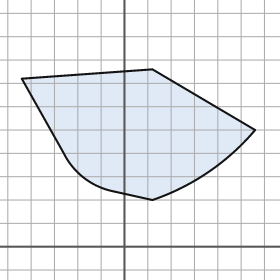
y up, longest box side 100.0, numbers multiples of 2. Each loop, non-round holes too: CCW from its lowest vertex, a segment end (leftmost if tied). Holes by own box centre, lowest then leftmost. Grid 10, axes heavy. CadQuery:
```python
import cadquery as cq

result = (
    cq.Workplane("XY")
    .moveTo(12.0, 20.0)
    .threePointArc((36.0, 32.0), (56.0, 50.0))
    .lineTo(12.0, 76.0)
    .lineTo(-44.0, 72.0)
    .lineTo(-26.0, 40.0)
    .threePointArc((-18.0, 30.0), (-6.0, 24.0))
    .close()
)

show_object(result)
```